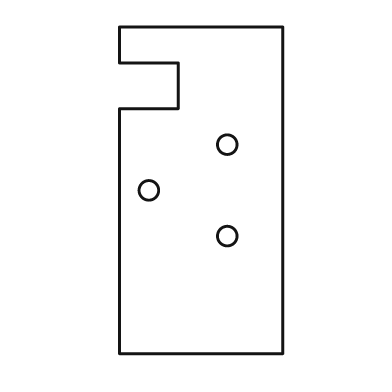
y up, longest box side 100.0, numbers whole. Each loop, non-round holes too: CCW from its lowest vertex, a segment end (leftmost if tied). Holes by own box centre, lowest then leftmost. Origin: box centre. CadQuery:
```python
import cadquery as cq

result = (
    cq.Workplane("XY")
    .moveTo(-25.0, -50.0)
    .lineTo(25.0, -50.0)
    .lineTo(25.0, 50.0)
    .lineTo(-25.0, 50.0)
    .lineTo(-25.0, 39.0)
    .lineTo(-7.0, 39.0)
    .lineTo(-7.0, 25.0)
    .lineTo(-25.0, 25.0)
    .close()
    .moveTo(8.0, -14.0)
    .circle(3.0)
    .moveTo(-16.0, 0.0)
    .circle(3.0)
    .moveTo(8.0, 14.0)
    .circle(3.0)
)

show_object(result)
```